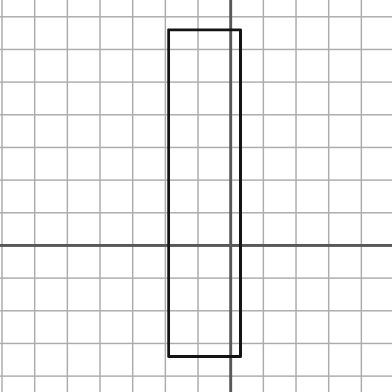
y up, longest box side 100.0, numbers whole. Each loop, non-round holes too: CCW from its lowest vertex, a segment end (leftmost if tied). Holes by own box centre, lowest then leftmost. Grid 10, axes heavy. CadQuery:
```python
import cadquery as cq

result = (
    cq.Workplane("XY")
    .moveTo(-19.0, -34.0)
    .lineTo(3.0, -34.0)
    .lineTo(3.0, 66.0)
    .lineTo(-19.0, 66.0)
    .close()
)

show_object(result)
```